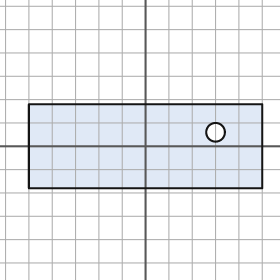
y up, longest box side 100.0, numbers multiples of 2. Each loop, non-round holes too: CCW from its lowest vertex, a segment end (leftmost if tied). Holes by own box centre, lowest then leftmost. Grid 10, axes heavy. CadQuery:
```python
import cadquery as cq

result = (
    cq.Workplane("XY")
    .moveTo(-50.0, -18.0)
    .lineTo(50.0, -18.0)
    .lineTo(50.0, 18.0)
    .lineTo(-50.0, 18.0)
    .close()
    .moveTo(30.0, 6.0)
    .circle(4.0)
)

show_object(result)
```